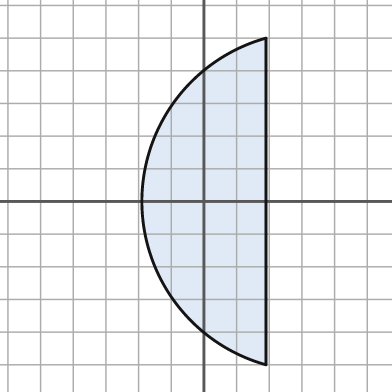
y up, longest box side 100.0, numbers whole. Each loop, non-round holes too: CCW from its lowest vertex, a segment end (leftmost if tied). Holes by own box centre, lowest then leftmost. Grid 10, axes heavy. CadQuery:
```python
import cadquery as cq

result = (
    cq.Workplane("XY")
    .moveTo(19.0, -50.0)
    .lineTo(19.0, 50.0)
    .threePointArc((-19.0, 0.0), (19.0, -50.0))
    .close()
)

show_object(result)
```